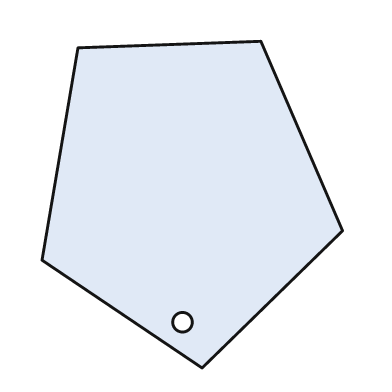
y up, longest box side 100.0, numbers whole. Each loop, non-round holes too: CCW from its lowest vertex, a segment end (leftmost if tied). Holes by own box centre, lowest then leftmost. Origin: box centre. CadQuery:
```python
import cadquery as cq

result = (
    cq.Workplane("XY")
    .moveTo(3.0, -50.0)
    .lineTo(46.0, -8.0)
    .lineTo(21.0, 50.0)
    .lineTo(-35.0, 48.0)
    .lineTo(-46.0, -17.0)
    .close()
    .moveTo(-3.0, -36.0)
    .circle(3.0)
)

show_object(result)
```